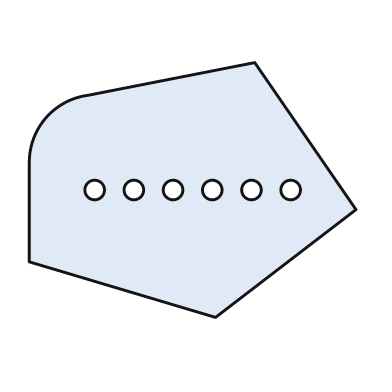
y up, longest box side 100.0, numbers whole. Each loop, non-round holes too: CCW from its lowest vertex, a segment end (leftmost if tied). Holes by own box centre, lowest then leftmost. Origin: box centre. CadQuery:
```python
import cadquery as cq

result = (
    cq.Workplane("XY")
    .moveTo(7.0, -39.0)
    .lineTo(50.0, -6.0)
    .lineTo(19.0, 39.0)
    .lineTo(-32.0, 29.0)
    .threePointArc((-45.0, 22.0), (-50.0, 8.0))
    .lineTo(-50.0, -22.0)
    .close()
    .moveTo(-30.0, 0.0)
    .circle(3.0)
    .moveTo(-18.0, 0.0)
    .circle(3.0)
    .moveTo(-6.0, 0.0)
    .circle(3.0)
    .moveTo(6.0, 0.0)
    .circle(3.0)
    .moveTo(18.0, 0.0)
    .circle(3.0)
    .moveTo(30.0, 0.0)
    .circle(3.0)
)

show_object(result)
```